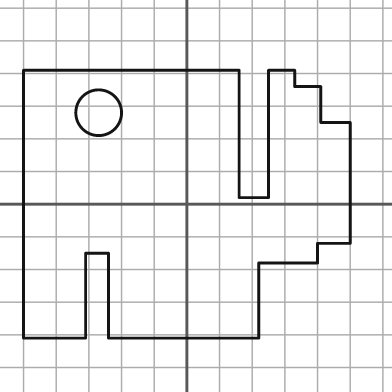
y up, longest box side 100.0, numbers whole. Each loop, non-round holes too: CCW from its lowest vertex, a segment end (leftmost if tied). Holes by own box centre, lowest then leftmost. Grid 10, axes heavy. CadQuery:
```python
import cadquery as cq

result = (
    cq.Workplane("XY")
    .moveTo(-50.0, -41.0)
    .lineTo(-31.0, -41.0)
    .lineTo(-31.0, -15.0)
    .lineTo(-24.0, -15.0)
    .lineTo(-24.0, -41.0)
    .lineTo(22.0, -41.0)
    .lineTo(22.0, -18.0)
    .lineTo(40.0, -18.0)
    .lineTo(40.0, -12.0)
    .lineTo(50.0, -12.0)
    .lineTo(50.0, 25.0)
    .lineTo(41.0, 25.0)
    .lineTo(41.0, 36.0)
    .lineTo(33.0, 36.0)
    .lineTo(33.0, 41.0)
    .lineTo(25.0, 41.0)
    .lineTo(25.0, 2.0)
    .lineTo(16.0, 2.0)
    .lineTo(16.0, 41.0)
    .lineTo(-50.0, 41.0)
    .close()
    .moveTo(-27.0, 28.0)
    .circle(7.0)
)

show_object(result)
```